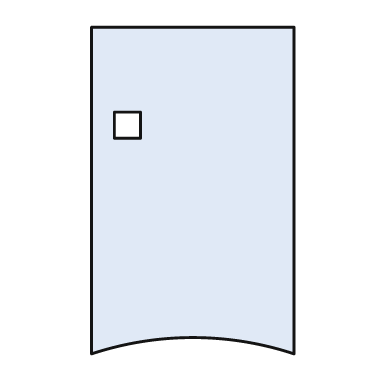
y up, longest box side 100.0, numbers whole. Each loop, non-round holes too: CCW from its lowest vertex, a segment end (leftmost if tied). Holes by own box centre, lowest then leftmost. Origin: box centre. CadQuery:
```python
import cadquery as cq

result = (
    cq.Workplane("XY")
    .moveTo(-31.0, -50.0)
    .threePointArc((0.0, -45.0), (31.0, -50.0))
    .lineTo(31.0, 50.0)
    .lineTo(-31.0, 50.0)
    .close()
    .moveTo(-24.0, 16.0)
    .lineTo(-16.0, 16.0)
    .lineTo(-16.0, 24.0)
    .lineTo(-24.0, 24.0)
    .close()
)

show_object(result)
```